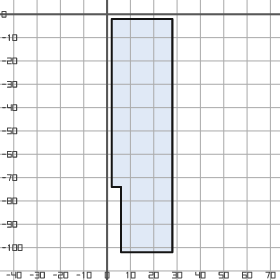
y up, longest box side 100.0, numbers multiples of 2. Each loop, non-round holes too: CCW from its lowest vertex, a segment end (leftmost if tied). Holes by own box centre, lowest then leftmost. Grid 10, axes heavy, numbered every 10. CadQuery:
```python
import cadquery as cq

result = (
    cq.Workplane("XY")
    .moveTo(6.0, -102.0)
    .lineTo(28.0, -102.0)
    .lineTo(28.0, -2.0)
    .lineTo(2.0, -2.0)
    .lineTo(2.0, -74.0)
    .lineTo(6.0, -74.0)
    .close()
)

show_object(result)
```